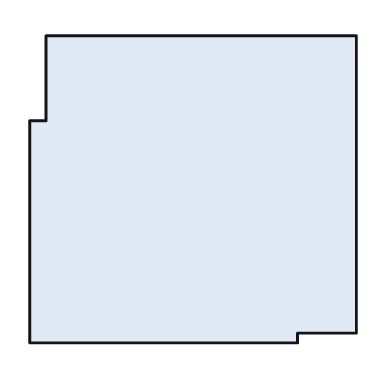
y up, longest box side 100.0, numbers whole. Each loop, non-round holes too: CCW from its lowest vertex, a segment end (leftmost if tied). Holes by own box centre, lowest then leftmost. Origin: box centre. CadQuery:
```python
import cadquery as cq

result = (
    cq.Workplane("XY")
    .moveTo(-50.0, -47.0)
    .lineTo(32.0, -47.0)
    .lineTo(32.0, -44.0)
    .lineTo(50.0, -44.0)
    .lineTo(50.0, 47.0)
    .lineTo(-45.0, 47.0)
    .lineTo(-45.0, 21.0)
    .lineTo(-50.0, 21.0)
    .close()
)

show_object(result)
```